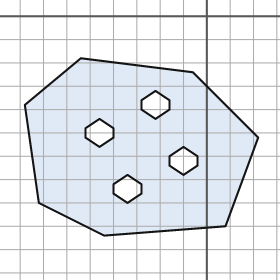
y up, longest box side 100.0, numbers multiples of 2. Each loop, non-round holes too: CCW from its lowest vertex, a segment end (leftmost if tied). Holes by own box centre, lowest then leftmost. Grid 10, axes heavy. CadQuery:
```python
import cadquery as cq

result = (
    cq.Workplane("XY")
    .moveTo(-44.0, -94.0)
    .lineTo(8.0, -90.0)
    .lineTo(22.0, -52.0)
    .lineTo(-6.0, -24.0)
    .lineTo(-54.0, -18.0)
    .lineTo(-78.0, -38.0)
    .lineTo(-72.0, -80.0)
    .close()
    .moveTo(-34.0, -80.0)
    .lineTo(-28.0, -76.0)
    .lineTo(-28.0, -72.0)
    .lineTo(-34.0, -68.0)
    .lineTo(-40.0, -72.0)
    .lineTo(-40.0, -76.0)
    .close()
    .moveTo(-10.0, -68.0)
    .lineTo(-4.0, -64.0)
    .lineTo(-4.0, -60.0)
    .lineTo(-10.0, -56.0)
    .lineTo(-16.0, -60.0)
    .lineTo(-16.0, -64.0)
    .close()
    .moveTo(-46.0, -56.0)
    .lineTo(-40.0, -52.0)
    .lineTo(-40.0, -48.0)
    .lineTo(-46.0, -44.0)
    .lineTo(-52.0, -48.0)
    .lineTo(-52.0, -52.0)
    .close()
    .moveTo(-22.0, -44.0)
    .lineTo(-16.0, -40.0)
    .lineTo(-16.0, -36.0)
    .lineTo(-22.0, -32.0)
    .lineTo(-28.0, -36.0)
    .lineTo(-28.0, -40.0)
    .close()
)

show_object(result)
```